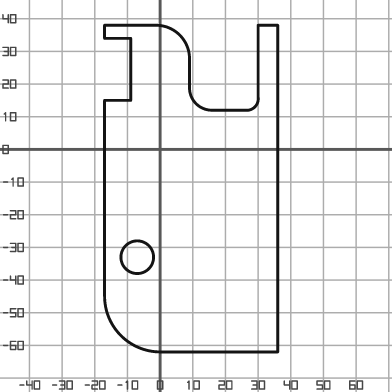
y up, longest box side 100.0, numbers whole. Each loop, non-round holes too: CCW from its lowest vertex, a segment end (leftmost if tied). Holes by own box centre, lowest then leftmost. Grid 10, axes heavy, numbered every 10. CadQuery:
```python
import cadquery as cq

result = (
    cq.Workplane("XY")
    .moveTo(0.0, -62.0)
    .lineTo(36.0, -62.0)
    .lineTo(36.0, 38.0)
    .lineTo(30.0, 38.0)
    .lineTo(30.0, 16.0)
    .threePointArc((29.0, 13.0), (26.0, 12.0))
    .lineTo(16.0, 12.0)
    .threePointArc((11.0, 14.0), (9.0, 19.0))
    .lineTo(9.0, 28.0)
    .threePointArc((6.0, 35.0), (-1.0, 38.0))
    .lineTo(-17.0, 38.0)
    .lineTo(-17.0, 34.0)
    .lineTo(-9.0, 34.0)
    .lineTo(-9.0, 15.0)
    .lineTo(-17.0, 15.0)
    .lineTo(-17.0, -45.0)
    .threePointArc((-12.0, -57.0), (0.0, -62.0))
    .close()
    .moveTo(-7.0, -33.0)
    .circle(5.0)
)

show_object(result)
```